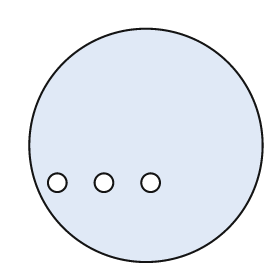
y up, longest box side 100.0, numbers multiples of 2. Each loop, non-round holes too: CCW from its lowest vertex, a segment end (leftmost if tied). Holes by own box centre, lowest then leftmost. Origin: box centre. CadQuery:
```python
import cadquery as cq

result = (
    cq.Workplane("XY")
    .moveTo(0.0, 0.0)
    .circle(50.0)
    .moveTo(-38.0, -16.0)
    .circle(4.0)
    .moveTo(-18.0, -16.0)
    .circle(4.0)
    .moveTo(2.0, -16.0)
    .circle(4.0)
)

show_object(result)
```